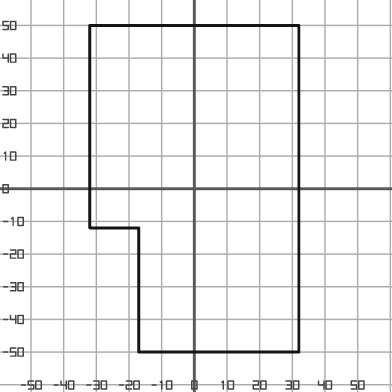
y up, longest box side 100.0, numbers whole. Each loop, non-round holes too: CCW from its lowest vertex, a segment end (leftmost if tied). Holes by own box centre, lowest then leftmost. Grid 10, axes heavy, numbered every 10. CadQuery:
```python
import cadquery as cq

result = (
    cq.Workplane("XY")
    .moveTo(-17.0, -50.0)
    .lineTo(32.0, -50.0)
    .lineTo(32.0, 50.0)
    .lineTo(-32.0, 50.0)
    .lineTo(-32.0, -12.0)
    .lineTo(-17.0, -12.0)
    .close()
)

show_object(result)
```